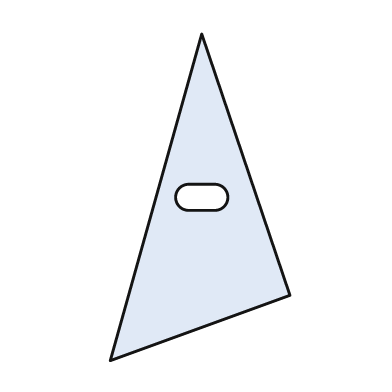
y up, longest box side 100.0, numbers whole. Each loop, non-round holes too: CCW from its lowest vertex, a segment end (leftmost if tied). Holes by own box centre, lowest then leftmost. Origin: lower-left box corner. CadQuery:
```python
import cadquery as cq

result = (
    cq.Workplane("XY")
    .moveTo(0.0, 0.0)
    .lineTo(55.0, 20.0)
    .lineTo(28.0, 100.0)
    .close()
    .moveTo(24.0, 46.0)
    .lineTo(32.0, 46.0)
    .threePointArc((36.0, 50.0), (32.0, 54.0))
    .lineTo(24.0, 54.0)
    .threePointArc((20.0, 50.0), (24.0, 46.0))
    .close()
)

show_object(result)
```